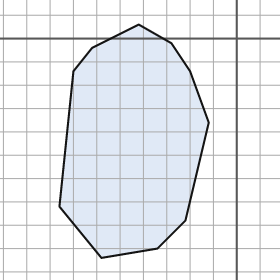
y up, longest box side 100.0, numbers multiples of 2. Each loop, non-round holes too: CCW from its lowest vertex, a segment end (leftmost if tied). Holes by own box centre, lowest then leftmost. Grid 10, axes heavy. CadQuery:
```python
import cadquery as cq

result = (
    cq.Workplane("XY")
    .moveTo(-58.0, -94.0)
    .lineTo(-34.0, -90.0)
    .lineTo(-22.0, -78.0)
    .lineTo(-12.0, -36.0)
    .lineTo(-20.0, -14.0)
    .lineTo(-28.0, -2.0)
    .lineTo(-42.0, 6.0)
    .lineTo(-62.0, -4.0)
    .lineTo(-70.0, -14.0)
    .lineTo(-76.0, -72.0)
    .close()
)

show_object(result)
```